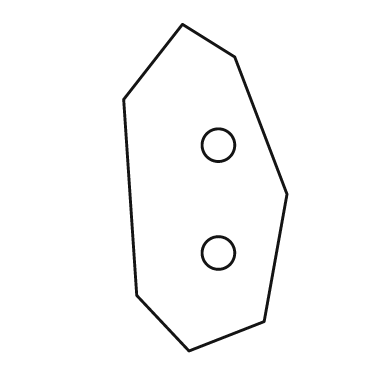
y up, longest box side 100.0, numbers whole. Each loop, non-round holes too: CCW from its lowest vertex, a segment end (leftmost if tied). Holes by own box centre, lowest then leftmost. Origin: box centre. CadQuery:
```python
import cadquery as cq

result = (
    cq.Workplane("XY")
    .moveTo(-5.0, -50.0)
    .lineTo(18.0, -41.0)
    .lineTo(25.0, -2.0)
    .lineTo(9.0, 40.0)
    .lineTo(-7.0, 50.0)
    .lineTo(-25.0, 27.0)
    .lineTo(-21.0, -33.0)
    .close()
    .moveTo(4.0, -20.0)
    .circle(5.0)
    .moveTo(4.0, 13.0)
    .circle(5.0)
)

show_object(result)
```